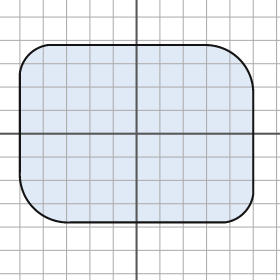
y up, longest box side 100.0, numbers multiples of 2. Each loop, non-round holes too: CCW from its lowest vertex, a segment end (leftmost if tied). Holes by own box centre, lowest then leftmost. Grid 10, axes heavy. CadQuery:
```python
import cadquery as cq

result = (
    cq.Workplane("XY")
    .moveTo(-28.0, -38.0)
    .lineTo(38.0, -38.0)
    .threePointArc((46.0, -34.0), (50.0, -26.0))
    .lineTo(50.0, 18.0)
    .threePointArc((44.0, 32.0), (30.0, 38.0))
    .lineTo(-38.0, 38.0)
    .threePointArc((-46.0, 34.0), (-50.0, 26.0))
    .lineTo(-50.0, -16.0)
    .threePointArc((-44.0, -32.0), (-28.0, -38.0))
    .close()
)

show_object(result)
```